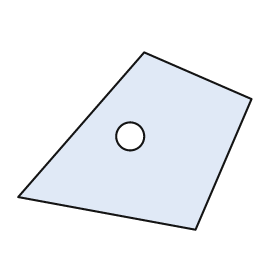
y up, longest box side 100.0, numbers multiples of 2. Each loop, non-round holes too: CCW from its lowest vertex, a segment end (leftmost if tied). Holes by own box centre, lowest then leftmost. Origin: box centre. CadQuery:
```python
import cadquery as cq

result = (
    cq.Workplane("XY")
    .moveTo(26.0, -38.0)
    .lineTo(50.0, 18.0)
    .lineTo(4.0, 38.0)
    .lineTo(-50.0, -24.0)
    .close()
    .moveTo(-2.0, 2.0)
    .circle(6.0)
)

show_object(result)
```